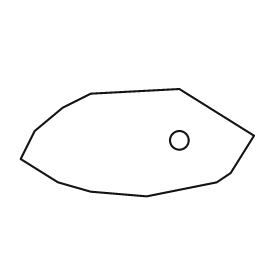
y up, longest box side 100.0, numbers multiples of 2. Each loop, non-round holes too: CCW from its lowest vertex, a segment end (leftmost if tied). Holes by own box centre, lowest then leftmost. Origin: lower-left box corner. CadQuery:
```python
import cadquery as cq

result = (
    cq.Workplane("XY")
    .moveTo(54.0, 0.0)
    .lineTo(84.0, 6.0)
    .lineTo(90.0, 10.0)
    .lineTo(100.0, 26.0)
    .lineTo(68.0, 46.0)
    .lineTo(30.0, 44.0)
    .lineTo(18.0, 38.0)
    .lineTo(6.0, 28.0)
    .lineTo(0.0, 16.0)
    .lineTo(16.0, 6.0)
    .lineTo(30.0, 2.0)
    .close()
    .moveTo(68.0, 24.0)
    .circle(4.0)
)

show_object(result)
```